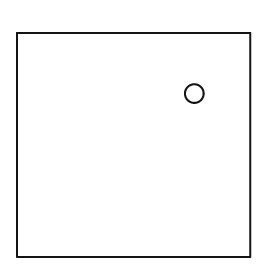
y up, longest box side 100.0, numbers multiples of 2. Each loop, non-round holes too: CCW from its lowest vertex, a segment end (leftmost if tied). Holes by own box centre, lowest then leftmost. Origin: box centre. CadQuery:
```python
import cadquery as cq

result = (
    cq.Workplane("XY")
    .moveTo(-50.0, -48.0)
    .lineTo(50.0, -48.0)
    .lineTo(50.0, 48.0)
    .lineTo(-50.0, 48.0)
    .close()
    .moveTo(26.0, 22.0)
    .circle(4.0)
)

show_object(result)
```